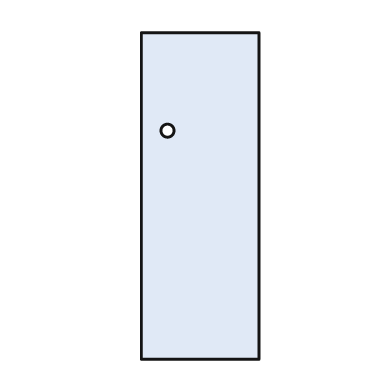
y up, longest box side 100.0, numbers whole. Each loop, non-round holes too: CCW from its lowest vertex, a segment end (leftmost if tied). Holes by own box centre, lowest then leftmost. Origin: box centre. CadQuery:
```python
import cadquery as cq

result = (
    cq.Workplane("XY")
    .moveTo(-18.0, -50.0)
    .lineTo(18.0, -50.0)
    .lineTo(18.0, 50.0)
    .lineTo(-18.0, 50.0)
    .close()
    .moveTo(-10.0, 20.0)
    .circle(2.0)
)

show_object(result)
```